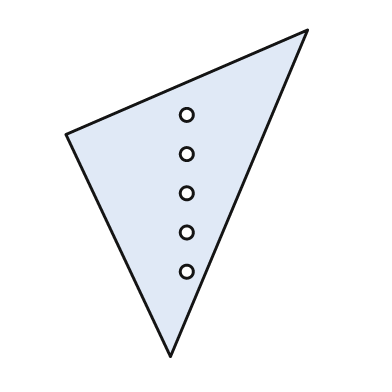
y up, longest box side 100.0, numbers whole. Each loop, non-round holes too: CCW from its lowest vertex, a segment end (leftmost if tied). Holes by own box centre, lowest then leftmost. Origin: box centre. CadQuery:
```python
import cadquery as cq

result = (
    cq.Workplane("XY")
    .moveTo(-5.0, -50.0)
    .lineTo(37.0, 50.0)
    .lineTo(-37.0, 18.0)
    .close()
    .moveTo(0.0, -24.0)
    .circle(2.0)
    .moveTo(0.0, -12.0)
    .circle(2.0)
    .moveTo(0.0, 0.0)
    .circle(2.0)
    .moveTo(0.0, 12.0)
    .circle(2.0)
    .moveTo(0.0, 24.0)
    .circle(2.0)
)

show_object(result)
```